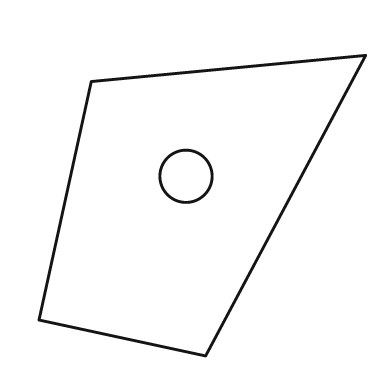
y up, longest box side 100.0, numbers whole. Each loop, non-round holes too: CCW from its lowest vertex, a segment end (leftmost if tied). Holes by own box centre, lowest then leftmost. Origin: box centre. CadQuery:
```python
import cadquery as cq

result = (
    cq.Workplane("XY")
    .moveTo(1.0, -46.0)
    .lineTo(50.0, 46.0)
    .lineTo(-34.0, 38.0)
    .lineTo(-50.0, -35.0)
    .close()
    .moveTo(-5.0, 9.0)
    .circle(8.0)
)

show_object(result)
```